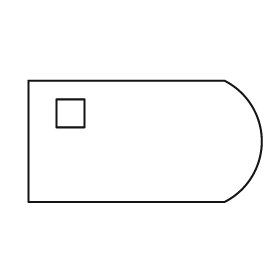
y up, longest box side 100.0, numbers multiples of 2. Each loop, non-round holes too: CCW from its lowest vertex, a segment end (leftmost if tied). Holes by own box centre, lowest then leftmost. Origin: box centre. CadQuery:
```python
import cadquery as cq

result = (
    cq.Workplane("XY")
    .moveTo(-50.0, -26.0)
    .lineTo(34.0, -26.0)
    .threePointArc((50.0, 0.0), (34.0, 26.0))
    .lineTo(-50.0, 26.0)
    .close()
    .moveTo(-38.0, 6.0)
    .lineTo(-26.0, 6.0)
    .lineTo(-26.0, 18.0)
    .lineTo(-38.0, 18.0)
    .close()
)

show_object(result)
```